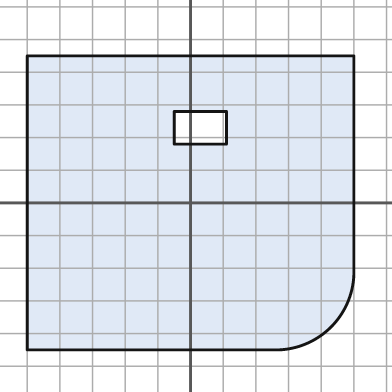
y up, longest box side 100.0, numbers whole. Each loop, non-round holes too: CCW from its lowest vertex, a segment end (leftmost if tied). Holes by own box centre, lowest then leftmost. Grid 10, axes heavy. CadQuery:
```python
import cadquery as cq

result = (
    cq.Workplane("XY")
    .moveTo(-50.0, -45.0)
    .lineTo(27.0, -45.0)
    .threePointArc((43.0, -38.0), (50.0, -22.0))
    .lineTo(50.0, 45.0)
    .lineTo(-50.0, 45.0)
    .close()
    .moveTo(-5.0, 18.0)
    .lineTo(11.0, 18.0)
    .lineTo(11.0, 28.0)
    .lineTo(-5.0, 28.0)
    .close()
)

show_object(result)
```